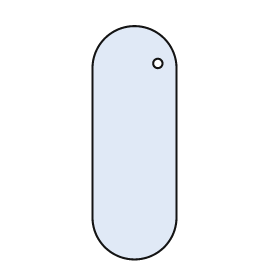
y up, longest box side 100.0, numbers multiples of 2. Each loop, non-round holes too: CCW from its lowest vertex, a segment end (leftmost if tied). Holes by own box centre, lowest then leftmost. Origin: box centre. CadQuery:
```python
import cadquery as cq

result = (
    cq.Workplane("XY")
    .moveTo(-18.0, -32.0)
    .threePointArc((0.0, -50.0), (18.0, -32.0))
    .lineTo(18.0, 32.0)
    .threePointArc((0.0, 50.0), (-18.0, 32.0))
    .close()
    .moveTo(10.0, 34.0)
    .circle(2.0)
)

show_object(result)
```